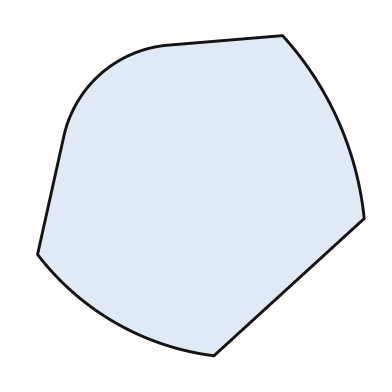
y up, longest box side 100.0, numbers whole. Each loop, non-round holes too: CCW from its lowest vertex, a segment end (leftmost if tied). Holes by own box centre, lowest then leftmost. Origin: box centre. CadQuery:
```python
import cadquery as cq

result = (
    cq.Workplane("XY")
    .moveTo(4.0, -49.0)
    .lineTo(50.0, -7.0)
    .threePointArc((42.0, 23.0), (25.0, 49.0))
    .lineTo(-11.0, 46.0)
    .threePointArc((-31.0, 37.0), (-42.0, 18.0))
    .lineTo(-50.0, -18.0)
    .threePointArc((-26.0, -39.0), (4.0, -49.0))
    .close()
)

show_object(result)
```